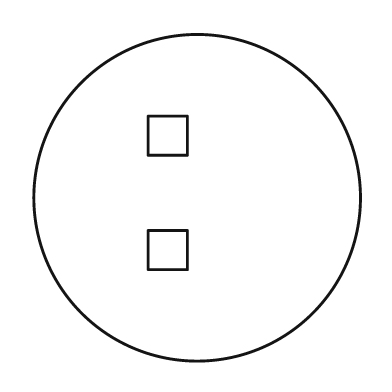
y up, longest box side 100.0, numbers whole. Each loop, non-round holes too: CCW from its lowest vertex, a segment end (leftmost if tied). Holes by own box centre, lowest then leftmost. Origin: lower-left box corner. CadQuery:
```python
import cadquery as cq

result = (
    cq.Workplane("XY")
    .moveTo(50.0, 50.0)
    .circle(50.0)
    .moveTo(35.0, 28.0)
    .lineTo(47.0, 28.0)
    .lineTo(47.0, 40.0)
    .lineTo(35.0, 40.0)
    .close()
    .moveTo(35.0, 63.0)
    .lineTo(47.0, 63.0)
    .lineTo(47.0, 75.0)
    .lineTo(35.0, 75.0)
    .close()
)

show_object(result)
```